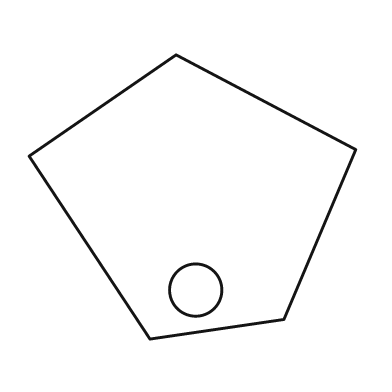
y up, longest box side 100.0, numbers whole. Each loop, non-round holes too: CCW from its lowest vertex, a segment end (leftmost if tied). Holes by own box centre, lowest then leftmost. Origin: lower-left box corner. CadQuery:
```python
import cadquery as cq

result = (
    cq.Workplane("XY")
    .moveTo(37.0, 0.0)
    .lineTo(78.0, 6.0)
    .lineTo(100.0, 58.0)
    .lineTo(45.0, 87.0)
    .lineTo(0.0, 56.0)
    .close()
    .moveTo(51.0, 15.0)
    .circle(8.0)
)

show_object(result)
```